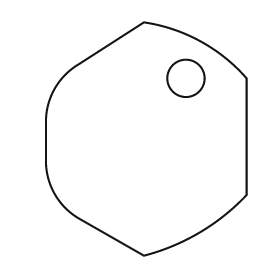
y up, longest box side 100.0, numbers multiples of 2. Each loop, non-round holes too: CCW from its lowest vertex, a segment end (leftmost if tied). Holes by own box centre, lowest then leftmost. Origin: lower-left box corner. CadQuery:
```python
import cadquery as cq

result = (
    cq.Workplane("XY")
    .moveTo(42.0, 0.0)
    .threePointArc((66.0, 10.0), (86.0, 26.0))
    .lineTo(86.0, 76.0)
    .threePointArc((66.0, 92.0), (42.0, 100.0))
    .lineTo(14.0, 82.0)
    .threePointArc((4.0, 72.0), (0.0, 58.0))
    .lineTo(0.0, 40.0)
    .threePointArc((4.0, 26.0), (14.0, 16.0))
    .close()
    .moveTo(60.0, 76.0)
    .circle(8.0)
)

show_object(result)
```